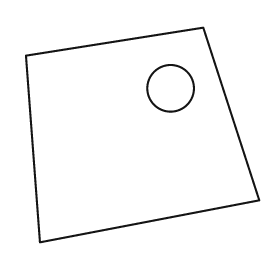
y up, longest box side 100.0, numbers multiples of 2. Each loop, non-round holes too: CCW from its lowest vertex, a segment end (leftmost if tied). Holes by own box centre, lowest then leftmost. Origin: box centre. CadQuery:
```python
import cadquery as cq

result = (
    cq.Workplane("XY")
    .moveTo(-44.0, -46.0)
    .lineTo(50.0, -28.0)
    .lineTo(26.0, 46.0)
    .lineTo(-50.0, 34.0)
    .close()
    .moveTo(12.0, 20.0)
    .circle(10.0)
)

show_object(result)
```